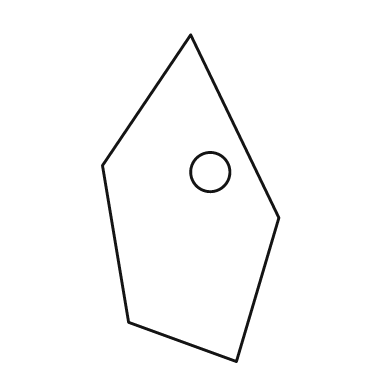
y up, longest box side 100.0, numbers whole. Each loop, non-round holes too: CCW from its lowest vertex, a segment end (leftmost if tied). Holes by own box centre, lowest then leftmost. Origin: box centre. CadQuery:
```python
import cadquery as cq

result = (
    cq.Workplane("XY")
    .moveTo(14.0, -50.0)
    .lineTo(27.0, -6.0)
    .lineTo(0.0, 50.0)
    .lineTo(-27.0, 10.0)
    .lineTo(-19.0, -38.0)
    .close()
    .moveTo(6.0, 8.0)
    .circle(6.0)
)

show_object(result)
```